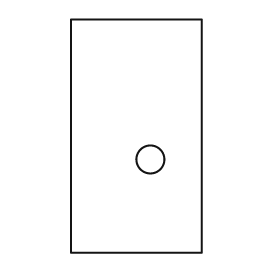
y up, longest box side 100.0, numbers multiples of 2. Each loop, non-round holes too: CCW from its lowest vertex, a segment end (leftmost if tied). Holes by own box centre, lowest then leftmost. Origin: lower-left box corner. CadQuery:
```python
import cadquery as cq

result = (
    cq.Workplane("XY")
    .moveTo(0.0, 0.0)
    .lineTo(56.0, 0.0)
    .lineTo(56.0, 100.0)
    .lineTo(0.0, 100.0)
    .close()
    .moveTo(34.0, 40.0)
    .circle(6.0)
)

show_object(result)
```